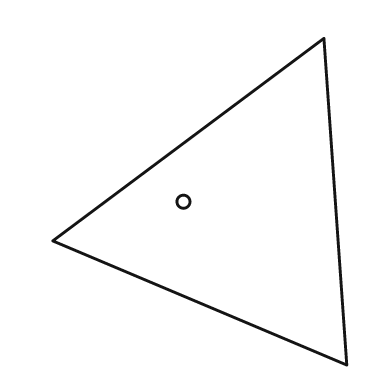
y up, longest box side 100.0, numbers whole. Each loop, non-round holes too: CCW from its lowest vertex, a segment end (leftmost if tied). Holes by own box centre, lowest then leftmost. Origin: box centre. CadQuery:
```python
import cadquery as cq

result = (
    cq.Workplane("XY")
    .moveTo(45.0, -50.0)
    .lineTo(38.0, 50.0)
    .lineTo(-45.0, -12.0)
    .close()
    .moveTo(-5.0, 0.0)
    .circle(2.0)
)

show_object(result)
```